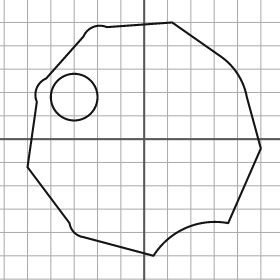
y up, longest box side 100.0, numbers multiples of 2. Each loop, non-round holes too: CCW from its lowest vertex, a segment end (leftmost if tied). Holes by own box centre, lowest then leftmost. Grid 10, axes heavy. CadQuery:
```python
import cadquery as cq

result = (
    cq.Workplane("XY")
    .moveTo(4.0, -50.0)
    .threePointArc((18.0, -38.0), (36.0, -36.0))
    .lineTo(50.0, -4.0)
    .lineTo(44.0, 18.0)
    .threePointArc((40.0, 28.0), (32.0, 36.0))
    .lineTo(12.0, 50.0)
    .lineTo(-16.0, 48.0)
    .threePointArc((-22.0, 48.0), (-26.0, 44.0))
    .lineTo(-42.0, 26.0)
    .threePointArc((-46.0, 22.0), (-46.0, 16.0))
    .lineTo(-50.0, -12.0)
    .lineTo(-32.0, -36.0)
    .threePointArc((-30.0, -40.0), (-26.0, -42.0))
    .close()
    .moveTo(-30.0, 18.0)
    .circle(10.0)
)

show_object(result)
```